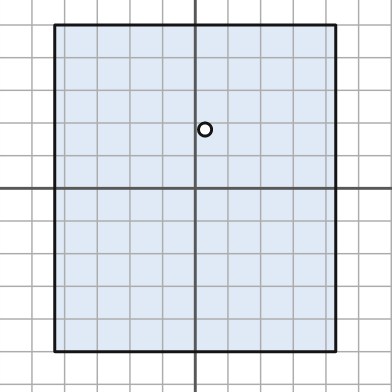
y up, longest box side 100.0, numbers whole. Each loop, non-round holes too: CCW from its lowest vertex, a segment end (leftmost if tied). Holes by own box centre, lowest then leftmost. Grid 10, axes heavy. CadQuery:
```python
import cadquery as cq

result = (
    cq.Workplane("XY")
    .moveTo(-43.0, -50.0)
    .lineTo(43.0, -50.0)
    .lineTo(43.0, 50.0)
    .lineTo(-43.0, 50.0)
    .close()
    .moveTo(3.0, 18.0)
    .circle(2.0)
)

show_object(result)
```